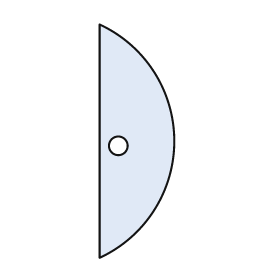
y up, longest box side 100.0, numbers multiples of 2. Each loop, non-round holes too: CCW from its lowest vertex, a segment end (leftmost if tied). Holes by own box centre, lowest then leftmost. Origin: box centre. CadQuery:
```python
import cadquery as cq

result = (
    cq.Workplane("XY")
    .moveTo(-16.0, -50.0)
    .threePointArc((16.0, 0.0), (-16.0, 50.0))
    .close()
    .moveTo(-8.0, -2.0)
    .circle(4.0)
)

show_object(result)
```